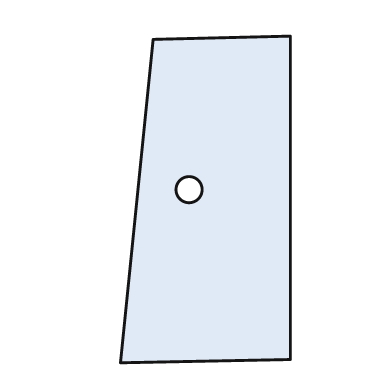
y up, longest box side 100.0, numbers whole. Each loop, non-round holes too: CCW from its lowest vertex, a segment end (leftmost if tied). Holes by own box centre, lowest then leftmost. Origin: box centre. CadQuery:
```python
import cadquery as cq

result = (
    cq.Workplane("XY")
    .moveTo(-26.0, -50.0)
    .lineTo(26.0, -49.0)
    .lineTo(26.0, 50.0)
    .lineTo(-16.0, 49.0)
    .close()
    .moveTo(-5.0, 3.0)
    .circle(4.0)
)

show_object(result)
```